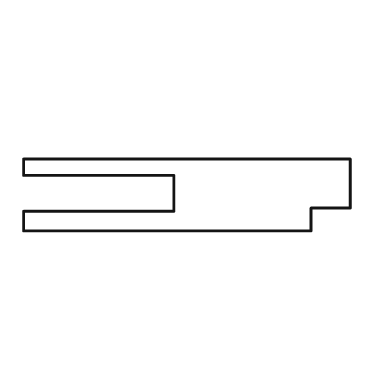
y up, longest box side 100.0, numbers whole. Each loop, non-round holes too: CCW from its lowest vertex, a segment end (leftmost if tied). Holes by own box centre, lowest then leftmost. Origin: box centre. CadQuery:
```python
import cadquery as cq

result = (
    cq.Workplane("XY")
    .moveTo(-50.0, -11.0)
    .lineTo(38.0, -11.0)
    .lineTo(38.0, -4.0)
    .lineTo(50.0, -4.0)
    .lineTo(50.0, 11.0)
    .lineTo(-50.0, 11.0)
    .lineTo(-50.0, 6.0)
    .lineTo(-4.0, 6.0)
    .lineTo(-4.0, -5.0)
    .lineTo(-50.0, -5.0)
    .close()
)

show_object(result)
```